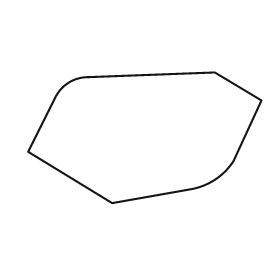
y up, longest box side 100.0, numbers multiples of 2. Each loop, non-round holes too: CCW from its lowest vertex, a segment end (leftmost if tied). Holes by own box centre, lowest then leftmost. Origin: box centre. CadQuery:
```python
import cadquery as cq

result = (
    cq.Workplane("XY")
    .moveTo(-14.0, -28.0)
    .lineTo(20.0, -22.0)
    .threePointArc((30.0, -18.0), (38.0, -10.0))
    .lineTo(50.0, 16.0)
    .lineTo(30.0, 28.0)
    .lineTo(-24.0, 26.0)
    .threePointArc((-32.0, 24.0), (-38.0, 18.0))
    .lineTo(-50.0, -6.0)
    .close()
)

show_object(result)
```